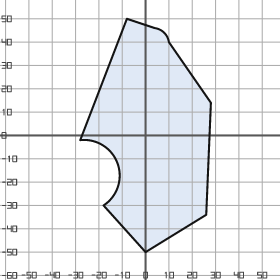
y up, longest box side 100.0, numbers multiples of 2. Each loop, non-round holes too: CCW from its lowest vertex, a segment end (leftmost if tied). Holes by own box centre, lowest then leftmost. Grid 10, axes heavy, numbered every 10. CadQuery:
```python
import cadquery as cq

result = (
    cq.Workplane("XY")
    .moveTo(0.0, -50.0)
    .lineTo(26.0, -34.0)
    .lineTo(28.0, 14.0)
    .lineTo(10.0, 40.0)
    .threePointArc((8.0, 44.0), (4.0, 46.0))
    .lineTo(-8.0, 50.0)
    .lineTo(-28.0, -2.0)
    .threePointArc((-12.0, -12.0), (-18.0, -30.0))
    .close()
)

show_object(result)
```